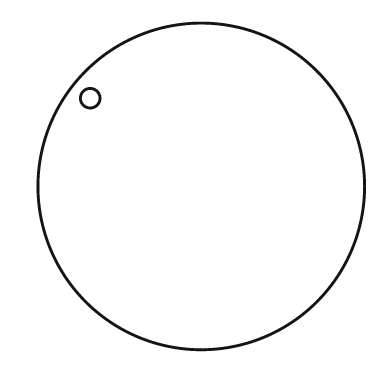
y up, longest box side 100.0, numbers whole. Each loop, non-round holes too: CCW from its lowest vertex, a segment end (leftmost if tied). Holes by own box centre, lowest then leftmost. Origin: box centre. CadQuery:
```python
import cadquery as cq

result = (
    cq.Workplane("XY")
    .moveTo(0.0, 0.0)
    .circle(50.0)
    .moveTo(-34.0, 27.0)
    .circle(3.0)
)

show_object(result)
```